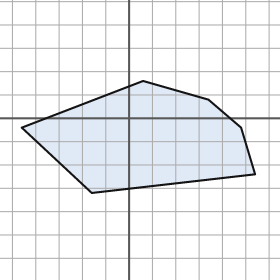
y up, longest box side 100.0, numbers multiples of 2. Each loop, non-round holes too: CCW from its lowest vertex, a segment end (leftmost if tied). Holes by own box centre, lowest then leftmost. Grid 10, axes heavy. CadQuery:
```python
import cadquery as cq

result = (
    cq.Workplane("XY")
    .moveTo(-16.0, -32.0)
    .lineTo(54.0, -24.0)
    .lineTo(48.0, -4.0)
    .lineTo(34.0, 8.0)
    .lineTo(6.0, 16.0)
    .lineTo(-46.0, -4.0)
    .close()
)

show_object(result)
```